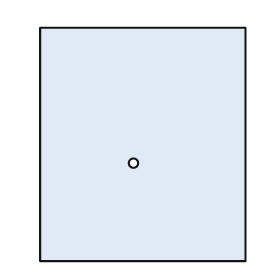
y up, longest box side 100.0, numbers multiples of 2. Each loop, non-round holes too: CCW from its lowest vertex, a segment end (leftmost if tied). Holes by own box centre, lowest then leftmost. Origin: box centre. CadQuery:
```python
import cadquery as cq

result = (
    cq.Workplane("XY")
    .moveTo(-44.0, -50.0)
    .lineTo(44.0, -50.0)
    .lineTo(44.0, 50.0)
    .lineTo(-44.0, 50.0)
    .close()
    .moveTo(-4.0, -8.0)
    .circle(2.0)
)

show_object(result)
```